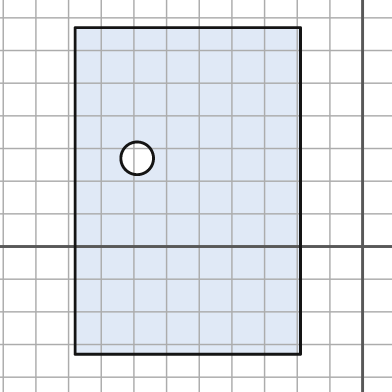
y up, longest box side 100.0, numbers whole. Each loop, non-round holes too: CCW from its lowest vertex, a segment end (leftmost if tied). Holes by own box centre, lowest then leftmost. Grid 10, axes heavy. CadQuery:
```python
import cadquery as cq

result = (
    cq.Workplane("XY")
    .moveTo(-88.0, -33.0)
    .lineTo(-19.0, -33.0)
    .lineTo(-19.0, 67.0)
    .lineTo(-88.0, 67.0)
    .close()
    .moveTo(-69.0, 27.0)
    .circle(5.0)
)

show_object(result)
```